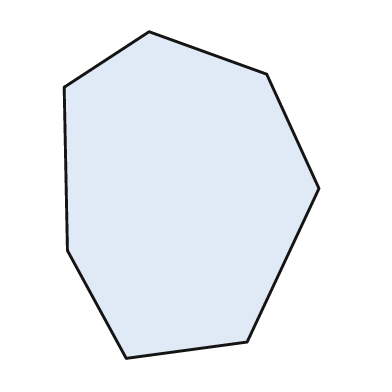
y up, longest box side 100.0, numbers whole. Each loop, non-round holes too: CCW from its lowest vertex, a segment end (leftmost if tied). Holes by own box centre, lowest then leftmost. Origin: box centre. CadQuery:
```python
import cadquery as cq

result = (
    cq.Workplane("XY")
    .moveTo(-20.0, -50.0)
    .lineTo(17.0, -45.0)
    .lineTo(39.0, 2.0)
    .lineTo(23.0, 37.0)
    .lineTo(-13.0, 50.0)
    .lineTo(-39.0, 33.0)
    .lineTo(-38.0, -17.0)
    .close()
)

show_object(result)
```